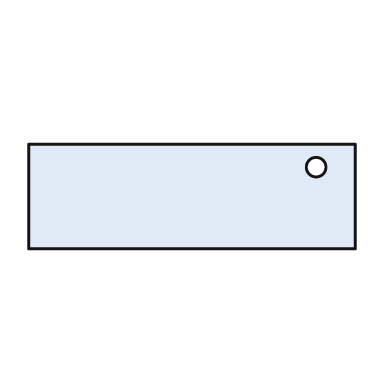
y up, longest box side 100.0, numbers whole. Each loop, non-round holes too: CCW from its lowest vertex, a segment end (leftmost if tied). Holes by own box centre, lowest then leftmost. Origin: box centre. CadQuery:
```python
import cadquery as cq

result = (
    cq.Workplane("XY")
    .moveTo(-50.0, -16.0)
    .lineTo(50.0, -16.0)
    .lineTo(50.0, 16.0)
    .lineTo(-50.0, 16.0)
    .close()
    .moveTo(38.0, 9.0)
    .circle(3.0)
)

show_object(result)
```